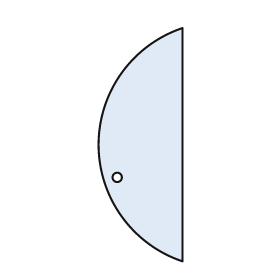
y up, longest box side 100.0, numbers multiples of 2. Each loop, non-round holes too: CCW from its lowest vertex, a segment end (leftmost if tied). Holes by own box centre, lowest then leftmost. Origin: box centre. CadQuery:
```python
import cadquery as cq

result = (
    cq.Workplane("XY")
    .moveTo(18.0, -50.0)
    .lineTo(18.0, 50.0)
    .threePointArc((-18.0, 0.0), (18.0, -50.0))
    .close()
    .moveTo(-10.0, -14.0)
    .circle(2.0)
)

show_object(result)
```